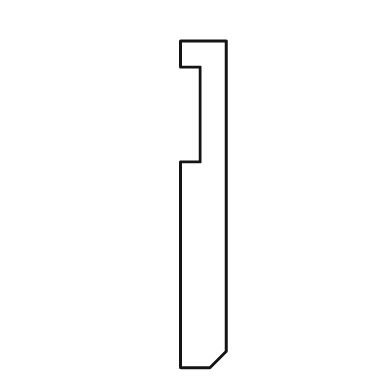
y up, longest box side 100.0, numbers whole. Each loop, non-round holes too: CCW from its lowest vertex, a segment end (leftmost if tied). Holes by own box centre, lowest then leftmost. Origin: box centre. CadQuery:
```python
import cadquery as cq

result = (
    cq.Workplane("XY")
    .moveTo(-7.0, -50.0)
    .lineTo(2.0, -50.0)
    .lineTo(7.0, -45.0)
    .lineTo(7.0, 50.0)
    .lineTo(-7.0, 50.0)
    .lineTo(-7.0, 42.0)
    .lineTo(-1.0, 42.0)
    .lineTo(-1.0, 13.0)
    .lineTo(-7.0, 13.0)
    .close()
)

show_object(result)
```